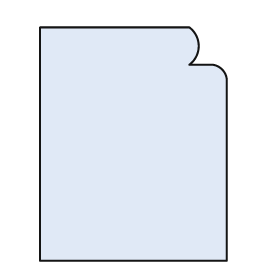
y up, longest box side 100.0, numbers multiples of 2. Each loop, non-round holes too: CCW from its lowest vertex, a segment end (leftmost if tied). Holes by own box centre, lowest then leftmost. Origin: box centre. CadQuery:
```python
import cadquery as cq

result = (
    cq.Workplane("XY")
    .moveTo(-40.0, -50.0)
    .lineTo(40.0, -50.0)
    .lineTo(40.0, 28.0)
    .threePointArc((38.0, 32.0), (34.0, 34.0))
    .lineTo(24.0, 34.0)
    .threePointArc((28.0, 42.0), (24.0, 50.0))
    .lineTo(-40.0, 50.0)
    .close()
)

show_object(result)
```